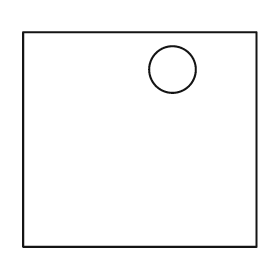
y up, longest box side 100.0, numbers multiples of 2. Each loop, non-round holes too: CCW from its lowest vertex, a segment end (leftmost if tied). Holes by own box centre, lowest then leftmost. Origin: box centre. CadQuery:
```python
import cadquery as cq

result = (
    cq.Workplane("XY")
    .moveTo(-50.0, -46.0)
    .lineTo(50.0, -46.0)
    .lineTo(50.0, 46.0)
    .lineTo(-50.0, 46.0)
    .close()
    .moveTo(14.0, 30.0)
    .circle(10.0)
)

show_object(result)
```